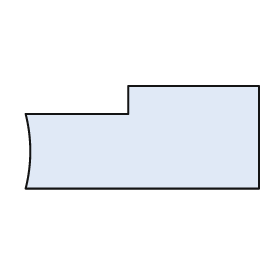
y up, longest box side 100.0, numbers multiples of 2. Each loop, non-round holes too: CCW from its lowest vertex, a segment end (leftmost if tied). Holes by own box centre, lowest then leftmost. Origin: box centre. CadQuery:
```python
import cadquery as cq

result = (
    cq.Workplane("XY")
    .moveTo(-50.0, -22.0)
    .lineTo(50.0, -22.0)
    .lineTo(50.0, 22.0)
    .lineTo(-6.0, 22.0)
    .lineTo(-6.0, 10.0)
    .lineTo(-50.0, 10.0)
    .threePointArc((-48.0, -6.0), (-50.0, -22.0))
    .close()
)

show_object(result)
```